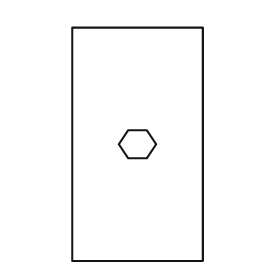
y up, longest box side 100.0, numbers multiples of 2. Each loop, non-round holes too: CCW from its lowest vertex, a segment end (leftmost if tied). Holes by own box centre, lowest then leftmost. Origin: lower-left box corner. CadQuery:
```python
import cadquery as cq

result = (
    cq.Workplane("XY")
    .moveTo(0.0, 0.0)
    .lineTo(56.0, 0.0)
    .lineTo(56.0, 100.0)
    .lineTo(0.0, 100.0)
    .close()
    .moveTo(24.0, 44.0)
    .lineTo(32.0, 44.0)
    .lineTo(36.0, 50.0)
    .lineTo(32.0, 56.0)
    .lineTo(24.0, 56.0)
    .lineTo(20.0, 50.0)
    .close()
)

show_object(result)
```